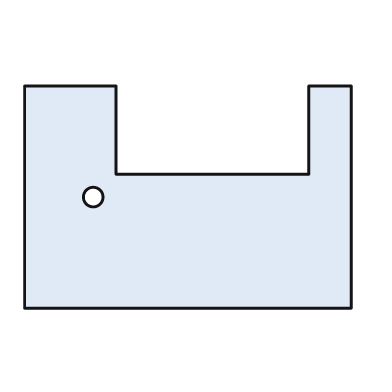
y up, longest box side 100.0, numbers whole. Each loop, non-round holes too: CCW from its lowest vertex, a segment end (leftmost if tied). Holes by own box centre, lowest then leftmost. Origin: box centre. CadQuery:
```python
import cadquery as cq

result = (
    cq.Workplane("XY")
    .moveTo(-50.0, -34.0)
    .lineTo(50.0, -34.0)
    .lineTo(50.0, 34.0)
    .lineTo(37.0, 34.0)
    .lineTo(37.0, 7.0)
    .lineTo(-22.0, 7.0)
    .lineTo(-22.0, 34.0)
    .lineTo(-50.0, 34.0)
    .close()
    .moveTo(-29.0, 0.0)
    .circle(3.0)
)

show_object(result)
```